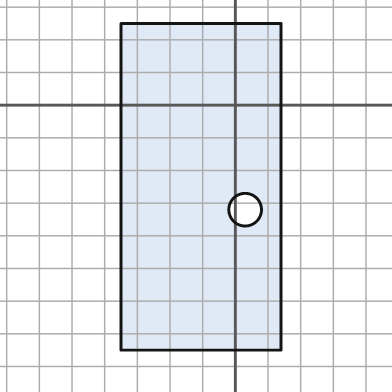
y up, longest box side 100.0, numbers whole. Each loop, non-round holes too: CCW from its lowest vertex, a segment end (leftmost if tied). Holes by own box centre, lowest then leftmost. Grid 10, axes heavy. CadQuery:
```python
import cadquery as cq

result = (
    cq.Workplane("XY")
    .moveTo(-35.0, -75.0)
    .lineTo(14.0, -75.0)
    .lineTo(14.0, 25.0)
    .lineTo(-35.0, 25.0)
    .close()
    .moveTo(3.0, -32.0)
    .circle(5.0)
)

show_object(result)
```